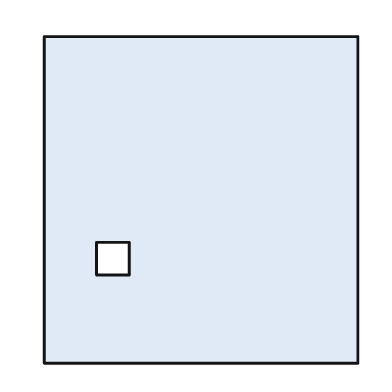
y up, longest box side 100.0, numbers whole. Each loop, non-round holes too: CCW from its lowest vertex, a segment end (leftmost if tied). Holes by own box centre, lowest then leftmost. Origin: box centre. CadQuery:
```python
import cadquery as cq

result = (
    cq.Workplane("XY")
    .moveTo(-48.0, -50.0)
    .lineTo(48.0, -50.0)
    .lineTo(48.0, 50.0)
    .lineTo(-48.0, 50.0)
    .close()
    .moveTo(-32.0, -23.0)
    .lineTo(-22.0, -23.0)
    .lineTo(-22.0, -13.0)
    .lineTo(-32.0, -13.0)
    .close()
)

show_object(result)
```